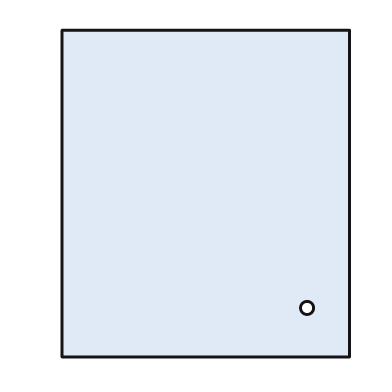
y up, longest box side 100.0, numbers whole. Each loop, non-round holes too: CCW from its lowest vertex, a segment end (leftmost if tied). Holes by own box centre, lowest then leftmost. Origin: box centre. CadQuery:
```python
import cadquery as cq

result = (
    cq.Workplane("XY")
    .moveTo(-44.0, -50.0)
    .lineTo(44.0, -50.0)
    .lineTo(44.0, 50.0)
    .lineTo(-44.0, 50.0)
    .close()
    .moveTo(31.0, -35.0)
    .circle(2.0)
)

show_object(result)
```